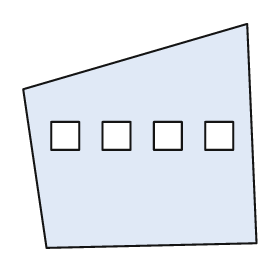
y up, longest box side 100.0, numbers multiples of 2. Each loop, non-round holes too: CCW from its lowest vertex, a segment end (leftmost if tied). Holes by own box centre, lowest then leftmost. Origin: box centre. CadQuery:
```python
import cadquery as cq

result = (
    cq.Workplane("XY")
    .moveTo(-40.0, -48.0)
    .lineTo(50.0, -46.0)
    .lineTo(46.0, 48.0)
    .lineTo(-50.0, 20.0)
    .close()
    .moveTo(-38.0, -6.0)
    .lineTo(-26.0, -6.0)
    .lineTo(-26.0, 6.0)
    .lineTo(-38.0, 6.0)
    .close()
    .moveTo(-16.0, -6.0)
    .lineTo(-4.0, -6.0)
    .lineTo(-4.0, 6.0)
    .lineTo(-16.0, 6.0)
    .close()
    .moveTo(6.0, -6.0)
    .lineTo(18.0, -6.0)
    .lineTo(18.0, 6.0)
    .lineTo(6.0, 6.0)
    .close()
    .moveTo(28.0, -6.0)
    .lineTo(40.0, -6.0)
    .lineTo(40.0, 6.0)
    .lineTo(28.0, 6.0)
    .close()
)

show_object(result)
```